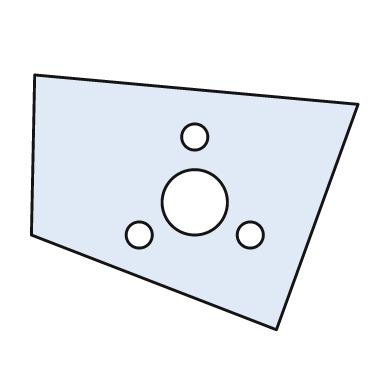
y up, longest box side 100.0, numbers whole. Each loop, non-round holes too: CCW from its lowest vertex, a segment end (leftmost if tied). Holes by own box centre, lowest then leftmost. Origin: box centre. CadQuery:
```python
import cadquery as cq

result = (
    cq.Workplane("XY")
    .moveTo(25.0, -39.0)
    .lineTo(50.0, 30.0)
    .lineTo(-49.0, 39.0)
    .lineTo(-50.0, -10.0)
    .close()
    .moveTo(-17.0, -10.0)
    .circle(4.0)
    .moveTo(17.0, -10.0)
    .circle(4.0)
    .moveTo(0.0, 0.0)
    .circle(10.0)
    .moveTo(0.0, 20.0)
    .circle(4.0)
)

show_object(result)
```